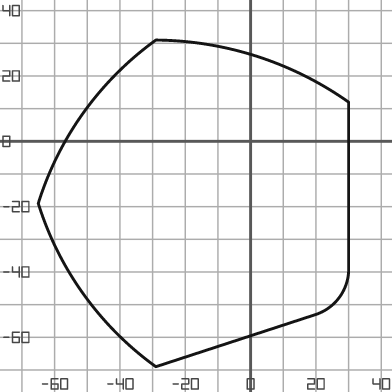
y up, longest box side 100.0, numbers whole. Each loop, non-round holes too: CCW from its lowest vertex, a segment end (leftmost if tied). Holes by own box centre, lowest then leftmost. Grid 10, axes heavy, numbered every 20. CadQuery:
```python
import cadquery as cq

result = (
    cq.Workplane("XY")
    .moveTo(-29.0, -69.0)
    .lineTo(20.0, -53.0)
    .threePointArc((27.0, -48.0), (30.0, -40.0))
    .lineTo(30.0, 12.0)
    .threePointArc((2.0, 26.0), (-29.0, 31.0))
    .threePointArc((-51.0, 9.0), (-65.0, -19.0))
    .threePointArc((-51.0, -47.0), (-29.0, -69.0))
    .close()
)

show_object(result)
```